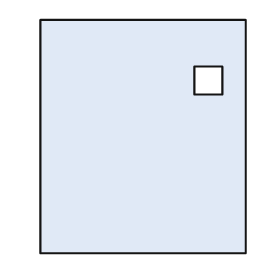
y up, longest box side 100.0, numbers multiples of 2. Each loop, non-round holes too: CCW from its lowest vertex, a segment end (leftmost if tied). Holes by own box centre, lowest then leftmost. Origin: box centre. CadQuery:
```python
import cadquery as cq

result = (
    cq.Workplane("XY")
    .moveTo(-44.0, -50.0)
    .lineTo(44.0, -50.0)
    .lineTo(44.0, 50.0)
    .lineTo(-44.0, 50.0)
    .close()
    .moveTo(22.0, 18.0)
    .lineTo(34.0, 18.0)
    .lineTo(34.0, 30.0)
    .lineTo(22.0, 30.0)
    .close()
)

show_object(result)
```